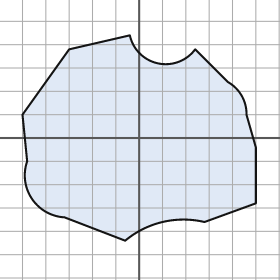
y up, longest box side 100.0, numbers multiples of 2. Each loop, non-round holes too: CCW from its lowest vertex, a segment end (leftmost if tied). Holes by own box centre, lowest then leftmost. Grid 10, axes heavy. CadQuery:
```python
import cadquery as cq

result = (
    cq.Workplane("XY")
    .moveTo(-6.0, -44.0)
    .threePointArc((10.0, -36.0), (28.0, -36.0))
    .lineTo(50.0, -28.0)
    .lineTo(50.0, -4.0)
    .lineTo(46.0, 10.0)
    .threePointArc((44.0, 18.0), (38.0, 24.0))
    .lineTo(24.0, 38.0)
    .threePointArc((8.0, 32.0), (-4.0, 44.0))
    .lineTo(-30.0, 38.0)
    .lineTo(-50.0, 10.0)
    .lineTo(-48.0, -10.0)
    .threePointArc((-46.0, -26.0), (-32.0, -34.0))
    .close()
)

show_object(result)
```